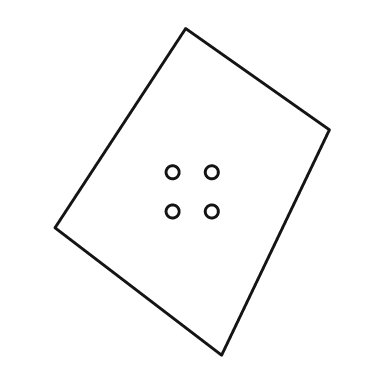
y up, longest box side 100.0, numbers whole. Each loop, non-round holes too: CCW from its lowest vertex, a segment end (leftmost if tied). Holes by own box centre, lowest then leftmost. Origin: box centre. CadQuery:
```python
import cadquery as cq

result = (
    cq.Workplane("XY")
    .moveTo(9.0, -50.0)
    .lineTo(42.0, 19.0)
    .lineTo(-2.0, 50.0)
    .lineTo(-42.0, -11.0)
    .close()
    .moveTo(-6.0, -6.0)
    .circle(2.0)
    .moveTo(6.0, -6.0)
    .circle(2.0)
    .moveTo(-6.0, 6.0)
    .circle(2.0)
    .moveTo(6.0, 6.0)
    .circle(2.0)
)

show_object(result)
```